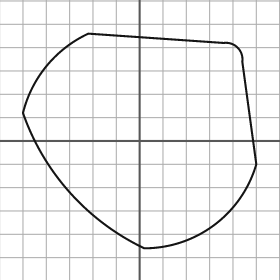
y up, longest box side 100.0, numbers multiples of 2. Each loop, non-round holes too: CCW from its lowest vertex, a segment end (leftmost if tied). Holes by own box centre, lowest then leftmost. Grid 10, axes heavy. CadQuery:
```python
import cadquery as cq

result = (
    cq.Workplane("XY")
    .moveTo(2.0, -46.0)
    .threePointArc((32.0, -36.0), (50.0, -10.0))
    .lineTo(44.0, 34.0)
    .threePointArc((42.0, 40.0), (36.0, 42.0))
    .lineTo(-22.0, 46.0)
    .threePointArc((-40.0, 32.0), (-50.0, 12.0))
    .threePointArc((-30.0, -22.0), (2.0, -46.0))
    .close()
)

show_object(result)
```